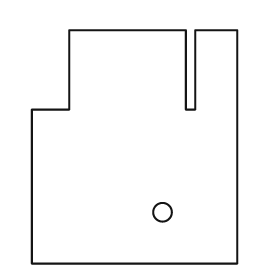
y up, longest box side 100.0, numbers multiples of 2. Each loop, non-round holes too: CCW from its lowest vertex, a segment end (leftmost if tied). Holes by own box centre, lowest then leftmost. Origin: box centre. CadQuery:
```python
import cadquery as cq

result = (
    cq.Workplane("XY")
    .moveTo(-44.0, -50.0)
    .lineTo(44.0, -50.0)
    .lineTo(44.0, 50.0)
    .lineTo(26.0, 50.0)
    .lineTo(26.0, 16.0)
    .lineTo(22.0, 16.0)
    .lineTo(22.0, 50.0)
    .lineTo(-28.0, 50.0)
    .lineTo(-28.0, 16.0)
    .lineTo(-44.0, 16.0)
    .close()
    .moveTo(12.0, -28.0)
    .circle(4.0)
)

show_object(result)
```